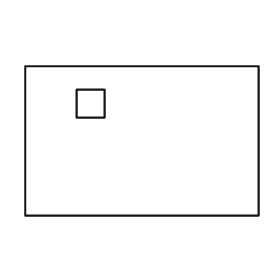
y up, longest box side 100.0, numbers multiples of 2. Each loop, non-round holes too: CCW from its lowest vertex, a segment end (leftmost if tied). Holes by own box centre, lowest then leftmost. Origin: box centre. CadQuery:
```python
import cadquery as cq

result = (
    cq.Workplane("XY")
    .moveTo(-50.0, -32.0)
    .lineTo(50.0, -32.0)
    .lineTo(50.0, 32.0)
    .lineTo(-50.0, 32.0)
    .close()
    .moveTo(-28.0, 10.0)
    .lineTo(-16.0, 10.0)
    .lineTo(-16.0, 22.0)
    .lineTo(-28.0, 22.0)
    .close()
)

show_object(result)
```